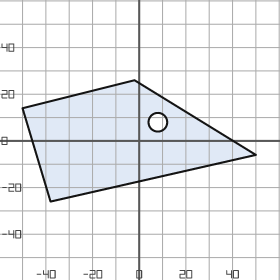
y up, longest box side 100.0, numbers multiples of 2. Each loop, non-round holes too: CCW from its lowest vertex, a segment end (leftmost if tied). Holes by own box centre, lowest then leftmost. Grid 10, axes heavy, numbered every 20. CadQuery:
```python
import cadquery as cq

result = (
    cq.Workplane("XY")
    .moveTo(-38.0, -26.0)
    .lineTo(50.0, -6.0)
    .lineTo(-2.0, 26.0)
    .lineTo(-50.0, 14.0)
    .close()
    .moveTo(8.0, 8.0)
    .circle(4.0)
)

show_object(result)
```